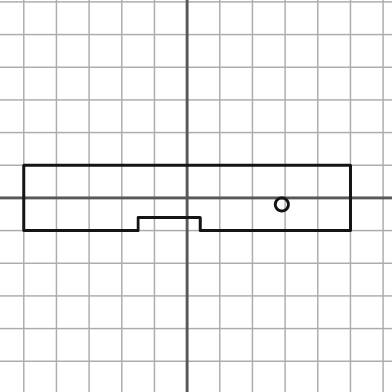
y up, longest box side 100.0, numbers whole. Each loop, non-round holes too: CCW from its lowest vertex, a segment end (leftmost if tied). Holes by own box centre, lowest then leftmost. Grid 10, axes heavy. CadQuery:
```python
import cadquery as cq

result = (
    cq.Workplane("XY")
    .moveTo(-50.0, -10.0)
    .lineTo(-15.0, -10.0)
    .lineTo(-15.0, -6.0)
    .lineTo(4.0, -6.0)
    .lineTo(4.0, -10.0)
    .lineTo(50.0, -10.0)
    .lineTo(50.0, 10.0)
    .lineTo(-50.0, 10.0)
    .close()
    .moveTo(29.0, -2.0)
    .circle(2.0)
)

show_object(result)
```